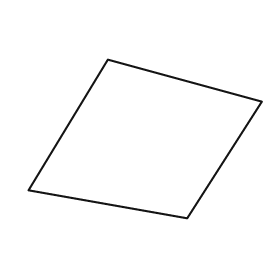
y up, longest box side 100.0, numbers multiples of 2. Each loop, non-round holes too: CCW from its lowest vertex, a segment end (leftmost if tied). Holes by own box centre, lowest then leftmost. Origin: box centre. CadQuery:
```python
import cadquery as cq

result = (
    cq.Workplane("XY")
    .moveTo(18.0, -34.0)
    .lineTo(50.0, 16.0)
    .lineTo(-16.0, 34.0)
    .lineTo(-50.0, -22.0)
    .close()
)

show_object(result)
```